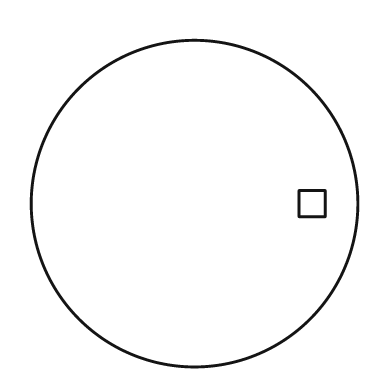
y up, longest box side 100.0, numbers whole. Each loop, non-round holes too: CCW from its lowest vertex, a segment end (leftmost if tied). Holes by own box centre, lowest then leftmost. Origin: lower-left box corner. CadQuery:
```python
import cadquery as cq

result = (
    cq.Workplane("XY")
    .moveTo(50.0, 50.0)
    .circle(50.0)
    .moveTo(82.0, 46.0)
    .lineTo(90.0, 46.0)
    .lineTo(90.0, 54.0)
    .lineTo(82.0, 54.0)
    .close()
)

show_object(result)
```